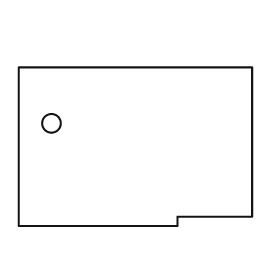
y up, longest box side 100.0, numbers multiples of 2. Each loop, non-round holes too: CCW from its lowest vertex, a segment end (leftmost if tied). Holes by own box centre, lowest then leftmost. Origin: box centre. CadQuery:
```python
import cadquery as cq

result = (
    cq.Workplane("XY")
    .moveTo(-50.0, -34.0)
    .lineTo(18.0, -34.0)
    .lineTo(18.0, -30.0)
    .lineTo(50.0, -30.0)
    .lineTo(50.0, 34.0)
    .lineTo(-50.0, 34.0)
    .close()
    .moveTo(-36.0, 10.0)
    .circle(4.0)
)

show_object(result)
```